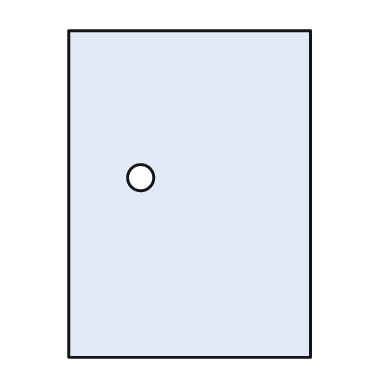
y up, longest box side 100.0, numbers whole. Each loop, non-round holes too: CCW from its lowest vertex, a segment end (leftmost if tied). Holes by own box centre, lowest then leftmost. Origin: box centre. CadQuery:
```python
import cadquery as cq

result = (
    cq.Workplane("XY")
    .moveTo(-37.0, -50.0)
    .lineTo(37.0, -50.0)
    .lineTo(37.0, 50.0)
    .lineTo(-37.0, 50.0)
    .close()
    .moveTo(-15.0, 5.0)
    .circle(4.0)
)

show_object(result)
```